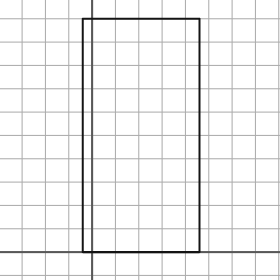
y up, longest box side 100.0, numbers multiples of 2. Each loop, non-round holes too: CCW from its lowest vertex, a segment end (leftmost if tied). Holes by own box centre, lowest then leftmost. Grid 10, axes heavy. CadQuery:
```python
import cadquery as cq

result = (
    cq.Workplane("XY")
    .moveTo(-4.0, 0.0)
    .lineTo(46.0, 0.0)
    .lineTo(46.0, 100.0)
    .lineTo(-4.0, 100.0)
    .close()
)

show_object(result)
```